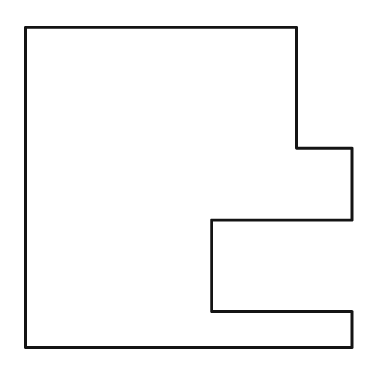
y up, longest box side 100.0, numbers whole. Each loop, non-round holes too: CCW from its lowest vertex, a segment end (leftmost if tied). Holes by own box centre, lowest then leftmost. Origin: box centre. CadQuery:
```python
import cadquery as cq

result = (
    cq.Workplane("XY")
    .moveTo(-50.0, -49.0)
    .lineTo(50.0, -49.0)
    .lineTo(50.0, -38.0)
    .lineTo(7.0, -38.0)
    .lineTo(7.0, -10.0)
    .lineTo(50.0, -10.0)
    .lineTo(50.0, 12.0)
    .lineTo(33.0, 12.0)
    .lineTo(33.0, 49.0)
    .lineTo(-50.0, 49.0)
    .close()
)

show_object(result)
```